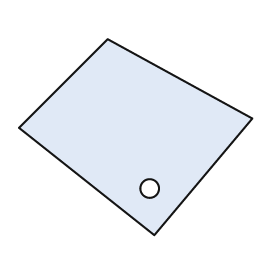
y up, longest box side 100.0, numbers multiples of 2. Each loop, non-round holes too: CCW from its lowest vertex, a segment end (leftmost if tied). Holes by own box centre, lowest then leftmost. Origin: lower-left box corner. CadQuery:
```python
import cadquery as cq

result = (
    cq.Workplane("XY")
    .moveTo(58.0, 0.0)
    .lineTo(100.0, 50.0)
    .lineTo(38.0, 84.0)
    .lineTo(0.0, 46.0)
    .close()
    .moveTo(56.0, 20.0)
    .circle(4.0)
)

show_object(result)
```